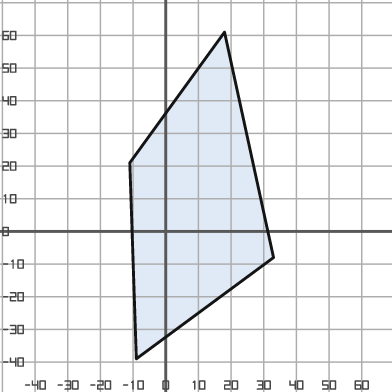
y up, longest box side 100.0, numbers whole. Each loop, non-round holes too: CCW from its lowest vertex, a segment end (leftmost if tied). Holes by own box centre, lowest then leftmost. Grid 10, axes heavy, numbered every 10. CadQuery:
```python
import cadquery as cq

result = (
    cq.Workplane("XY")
    .moveTo(-9.0, -39.0)
    .lineTo(33.0, -8.0)
    .lineTo(18.0, 61.0)
    .lineTo(-11.0, 21.0)
    .close()
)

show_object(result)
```